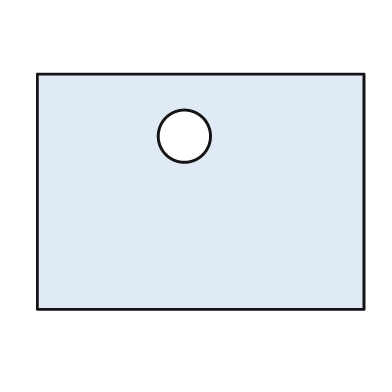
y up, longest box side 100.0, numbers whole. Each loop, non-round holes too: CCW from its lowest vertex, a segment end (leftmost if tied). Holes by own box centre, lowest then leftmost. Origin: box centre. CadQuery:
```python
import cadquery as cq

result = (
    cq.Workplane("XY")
    .moveTo(-50.0, -36.0)
    .lineTo(50.0, -36.0)
    .lineTo(50.0, 36.0)
    .lineTo(-50.0, 36.0)
    .close()
    .moveTo(-5.0, 17.0)
    .circle(8.0)
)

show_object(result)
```